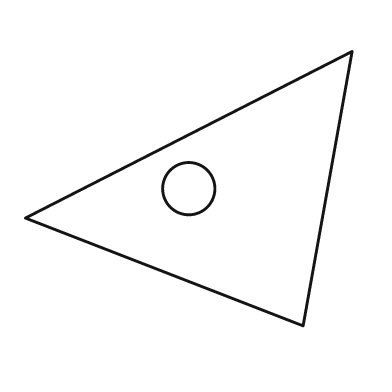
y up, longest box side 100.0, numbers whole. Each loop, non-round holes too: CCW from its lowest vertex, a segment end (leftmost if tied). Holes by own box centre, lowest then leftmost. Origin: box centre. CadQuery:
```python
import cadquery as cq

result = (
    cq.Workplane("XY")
    .moveTo(35.0, -42.0)
    .lineTo(50.0, 42.0)
    .lineTo(-50.0, -9.0)
    .close()
    .moveTo(0.0, 0.0)
    .circle(8.0)
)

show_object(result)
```